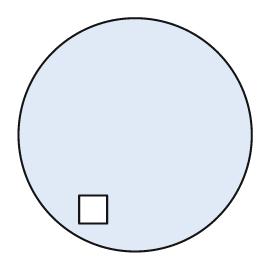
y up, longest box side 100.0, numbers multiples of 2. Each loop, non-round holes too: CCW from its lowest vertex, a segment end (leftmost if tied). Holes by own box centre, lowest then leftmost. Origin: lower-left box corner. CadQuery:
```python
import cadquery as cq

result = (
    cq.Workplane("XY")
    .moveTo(50.0, 50.0)
    .circle(50.0)
    .moveTo(26.0, 12.0)
    .lineTo(38.0, 12.0)
    .lineTo(38.0, 24.0)
    .lineTo(26.0, 24.0)
    .close()
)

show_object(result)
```